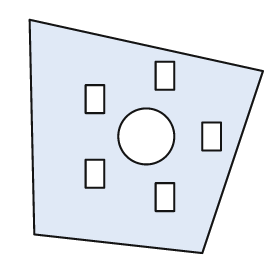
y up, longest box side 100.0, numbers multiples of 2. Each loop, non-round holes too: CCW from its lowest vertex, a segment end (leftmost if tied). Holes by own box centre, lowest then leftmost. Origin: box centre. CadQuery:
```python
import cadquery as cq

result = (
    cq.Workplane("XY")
    .moveTo(24.0, -50.0)
    .lineTo(50.0, 28.0)
    .lineTo(-50.0, 50.0)
    .lineTo(-48.0, -42.0)
    .close()
    .moveTo(4.0, -32.0)
    .lineTo(12.0, -32.0)
    .lineTo(12.0, -20.0)
    .lineTo(4.0, -20.0)
    .close()
    .moveTo(-26.0, -22.0)
    .lineTo(-18.0, -22.0)
    .lineTo(-18.0, -10.0)
    .lineTo(-26.0, -10.0)
    .close()
    .moveTo(0.0, 0.0)
    .circle(12.0)
    .moveTo(24.0, -6.0)
    .lineTo(32.0, -6.0)
    .lineTo(32.0, 6.0)
    .lineTo(24.0, 6.0)
    .close()
    .moveTo(-26.0, 10.0)
    .lineTo(-18.0, 10.0)
    .lineTo(-18.0, 22.0)
    .lineTo(-26.0, 22.0)
    .close()
    .moveTo(4.0, 20.0)
    .lineTo(12.0, 20.0)
    .lineTo(12.0, 32.0)
    .lineTo(4.0, 32.0)
    .close()
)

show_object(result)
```